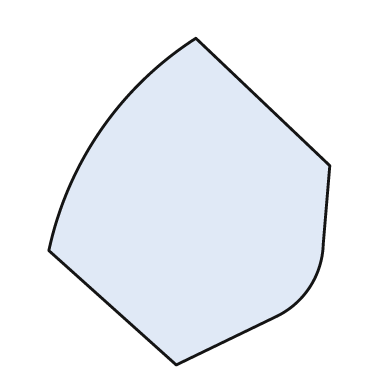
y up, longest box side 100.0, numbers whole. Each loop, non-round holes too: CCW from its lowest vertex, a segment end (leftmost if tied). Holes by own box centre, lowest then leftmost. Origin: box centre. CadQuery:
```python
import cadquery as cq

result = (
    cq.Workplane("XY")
    .moveTo(-4.0, -50.0)
    .lineTo(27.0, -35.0)
    .threePointArc((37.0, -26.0), (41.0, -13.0))
    .lineTo(43.0, 11.0)
    .lineTo(2.0, 50.0)
    .threePointArc((-27.0, 22.0), (-43.0, -15.0))
    .close()
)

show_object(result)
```